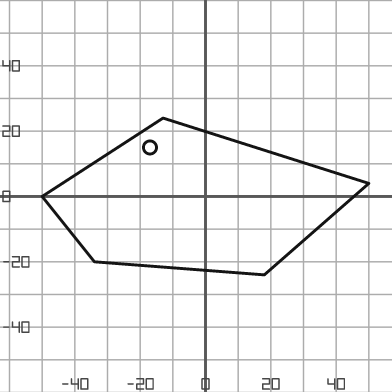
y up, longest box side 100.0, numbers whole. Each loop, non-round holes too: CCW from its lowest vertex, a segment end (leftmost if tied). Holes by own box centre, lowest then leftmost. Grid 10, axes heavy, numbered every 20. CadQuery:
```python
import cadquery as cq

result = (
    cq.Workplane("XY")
    .moveTo(18.0, -24.0)
    .lineTo(50.0, 4.0)
    .lineTo(-13.0, 24.0)
    .lineTo(-50.0, 0.0)
    .lineTo(-34.0, -20.0)
    .close()
    .moveTo(-17.0, 15.0)
    .circle(2.0)
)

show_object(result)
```